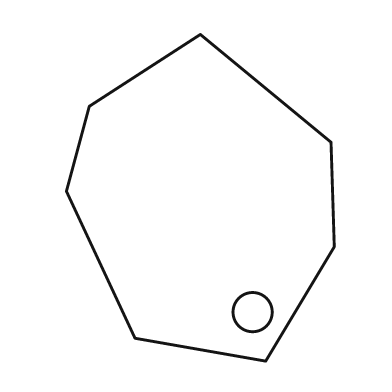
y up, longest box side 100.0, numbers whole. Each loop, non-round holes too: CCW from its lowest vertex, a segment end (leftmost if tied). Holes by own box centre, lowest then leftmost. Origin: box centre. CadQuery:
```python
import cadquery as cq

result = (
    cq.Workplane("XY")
    .moveTo(20.0, -50.0)
    .lineTo(41.0, -15.0)
    .lineTo(40.0, 17.0)
    .lineTo(0.0, 50.0)
    .lineTo(-34.0, 28.0)
    .lineTo(-41.0, 2.0)
    .lineTo(-20.0, -43.0)
    .close()
    .moveTo(16.0, -35.0)
    .circle(6.0)
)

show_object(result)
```